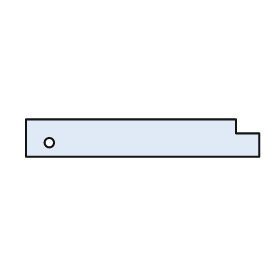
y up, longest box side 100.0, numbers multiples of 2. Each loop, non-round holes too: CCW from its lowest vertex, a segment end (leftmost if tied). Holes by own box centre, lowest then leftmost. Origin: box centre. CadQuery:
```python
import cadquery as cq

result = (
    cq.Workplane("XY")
    .moveTo(-50.0, -8.0)
    .lineTo(50.0, -8.0)
    .lineTo(50.0, 2.0)
    .lineTo(40.0, 2.0)
    .lineTo(40.0, 8.0)
    .lineTo(-50.0, 8.0)
    .close()
    .moveTo(-40.0, -2.0)
    .circle(2.0)
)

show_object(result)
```